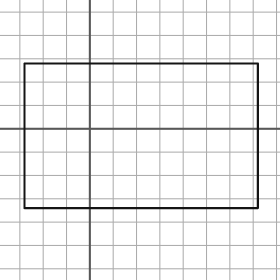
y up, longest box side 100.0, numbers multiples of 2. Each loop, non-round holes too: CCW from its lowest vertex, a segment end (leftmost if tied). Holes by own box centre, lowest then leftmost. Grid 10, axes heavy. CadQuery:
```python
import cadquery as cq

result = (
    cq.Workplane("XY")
    .moveTo(-28.0, -34.0)
    .lineTo(72.0, -34.0)
    .lineTo(72.0, 28.0)
    .lineTo(-28.0, 28.0)
    .close()
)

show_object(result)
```